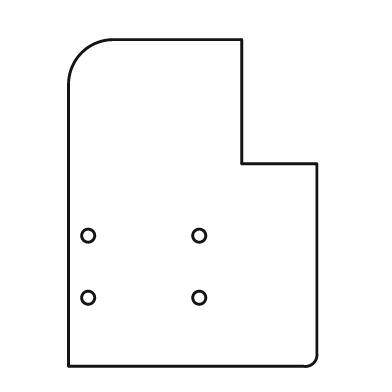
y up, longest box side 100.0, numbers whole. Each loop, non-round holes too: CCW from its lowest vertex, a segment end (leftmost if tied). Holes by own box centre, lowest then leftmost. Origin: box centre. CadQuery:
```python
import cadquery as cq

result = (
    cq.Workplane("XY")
    .moveTo(-38.0, -50.0)
    .lineTo(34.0, -50.0)
    .threePointArc((37.0, -49.0), (38.0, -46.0))
    .lineTo(38.0, 12.0)
    .lineTo(15.0, 12.0)
    .lineTo(15.0, 50.0)
    .lineTo(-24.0, 50.0)
    .threePointArc((-34.0, 46.0), (-38.0, 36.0))
    .close()
    .moveTo(-32.0, -29.0)
    .circle(2.0)
    .moveTo(2.0, -29.0)
    .circle(2.0)
    .moveTo(-32.0, -10.0)
    .circle(2.0)
    .moveTo(2.0, -10.0)
    .circle(2.0)
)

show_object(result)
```